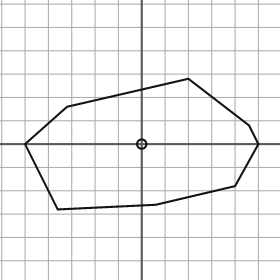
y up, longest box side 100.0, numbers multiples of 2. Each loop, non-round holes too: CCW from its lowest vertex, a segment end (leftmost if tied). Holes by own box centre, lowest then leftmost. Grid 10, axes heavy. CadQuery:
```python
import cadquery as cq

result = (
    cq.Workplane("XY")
    .moveTo(-36.0, -28.0)
    .lineTo(6.0, -26.0)
    .lineTo(40.0, -18.0)
    .lineTo(50.0, 0.0)
    .lineTo(46.0, 8.0)
    .lineTo(20.0, 28.0)
    .lineTo(-32.0, 16.0)
    .lineTo(-50.0, 0.0)
    .close()
    .moveTo(0.0, 0.0)
    .circle(2.0)
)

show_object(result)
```